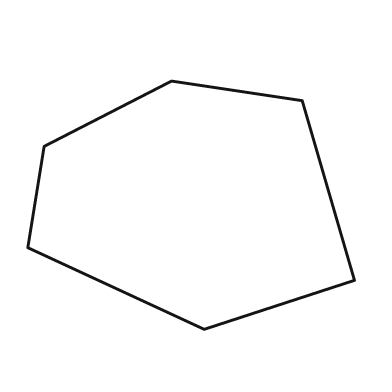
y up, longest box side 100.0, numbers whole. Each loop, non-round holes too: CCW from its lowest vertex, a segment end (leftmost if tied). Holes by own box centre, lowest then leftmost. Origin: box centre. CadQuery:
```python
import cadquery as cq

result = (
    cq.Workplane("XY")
    .moveTo(4.0, -38.0)
    .lineTo(50.0, -23.0)
    .lineTo(34.0, 32.0)
    .lineTo(-6.0, 38.0)
    .lineTo(-45.0, 18.0)
    .lineTo(-50.0, -13.0)
    .close()
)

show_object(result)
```